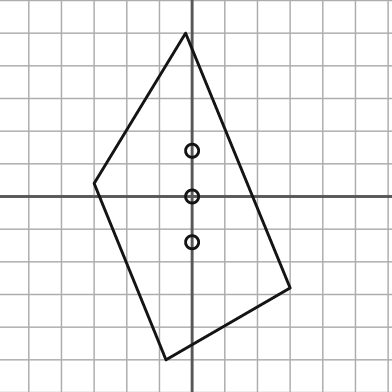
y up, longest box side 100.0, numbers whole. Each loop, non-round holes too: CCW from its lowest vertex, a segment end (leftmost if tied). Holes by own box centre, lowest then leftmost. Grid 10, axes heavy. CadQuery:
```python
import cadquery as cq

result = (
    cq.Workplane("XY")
    .moveTo(-8.0, -50.0)
    .lineTo(30.0, -28.0)
    .lineTo(-2.0, 50.0)
    .lineTo(-30.0, 4.0)
    .close()
    .moveTo(0.0, -14.0)
    .circle(2.0)
    .moveTo(0.0, 0.0)
    .circle(2.0)
    .moveTo(0.0, 14.0)
    .circle(2.0)
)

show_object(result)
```